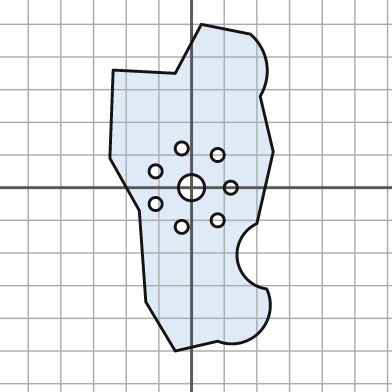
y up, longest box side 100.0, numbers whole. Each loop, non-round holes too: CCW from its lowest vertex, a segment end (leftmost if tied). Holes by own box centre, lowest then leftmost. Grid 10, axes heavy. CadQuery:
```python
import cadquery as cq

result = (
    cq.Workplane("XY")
    .moveTo(-5.0, -50.0)
    .lineTo(8.0, -47.0)
    .threePointArc((21.0, -44.0), (23.0, -31.0))
    .threePointArc((14.0, -22.0), (20.0, -11.0))
    .lineTo(25.0, 11.0)
    .lineTo(21.0, 28.0)
    .threePointArc((23.0, 38.0), (18.0, 47.0))
    .lineTo(3.0, 50.0)
    .lineTo(-5.0, 35.0)
    .lineTo(-24.0, 36.0)
    .lineTo(-25.0, 9.0)
    .lineTo(-16.0, -7.0)
    .lineTo(-14.0, -35.0)
    .close()
    .moveTo(-3.0, -12.0)
    .circle(2.0)
    .moveTo(8.0, -10.0)
    .circle(2.0)
    .moveTo(-11.0, -5.0)
    .circle(2.0)
    .moveTo(0.0, 0.0)
    .circle(4.0)
    .moveTo(12.0, 0.0)
    .circle(2.0)
    .moveTo(-11.0, 5.0)
    .circle(2.0)
    .moveTo(8.0, 10.0)
    .circle(2.0)
    .moveTo(-3.0, 12.0)
    .circle(2.0)
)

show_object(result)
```